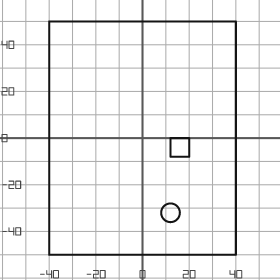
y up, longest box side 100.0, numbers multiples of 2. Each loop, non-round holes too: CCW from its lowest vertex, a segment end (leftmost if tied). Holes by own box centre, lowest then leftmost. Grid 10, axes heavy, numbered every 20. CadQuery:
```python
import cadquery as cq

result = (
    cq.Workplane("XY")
    .moveTo(-40.0, -50.0)
    .lineTo(40.0, -50.0)
    .lineTo(40.0, 50.0)
    .lineTo(-40.0, 50.0)
    .close()
    .moveTo(12.0, -32.0)
    .circle(4.0)
    .moveTo(12.0, -8.0)
    .lineTo(20.0, -8.0)
    .lineTo(20.0, 0.0)
    .lineTo(12.0, 0.0)
    .close()
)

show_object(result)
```